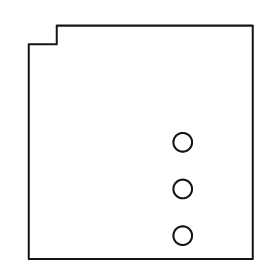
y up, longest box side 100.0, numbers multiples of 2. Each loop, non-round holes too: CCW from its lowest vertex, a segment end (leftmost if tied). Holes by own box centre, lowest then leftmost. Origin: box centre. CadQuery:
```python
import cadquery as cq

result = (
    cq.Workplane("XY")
    .moveTo(-48.0, -50.0)
    .lineTo(48.0, -50.0)
    .lineTo(48.0, 50.0)
    .lineTo(-36.0, 50.0)
    .lineTo(-36.0, 42.0)
    .lineTo(-48.0, 42.0)
    .close()
    .moveTo(18.0, -40.0)
    .circle(4.0)
    .moveTo(18.0, -20.0)
    .circle(4.0)
    .moveTo(18.0, 0.0)
    .circle(4.0)
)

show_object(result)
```